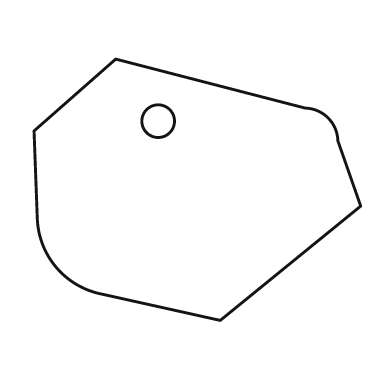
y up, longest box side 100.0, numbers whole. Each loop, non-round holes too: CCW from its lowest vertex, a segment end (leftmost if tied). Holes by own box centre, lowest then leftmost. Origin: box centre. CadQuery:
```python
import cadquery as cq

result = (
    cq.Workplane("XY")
    .moveTo(7.0, -40.0)
    .lineTo(50.0, -5.0)
    .lineTo(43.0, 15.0)
    .threePointArc((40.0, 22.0), (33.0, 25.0))
    .lineTo(-25.0, 40.0)
    .lineTo(-50.0, 18.0)
    .lineTo(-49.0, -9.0)
    .threePointArc((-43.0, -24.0), (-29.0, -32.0))
    .close()
    .moveTo(-12.0, 21.0)
    .circle(5.0)
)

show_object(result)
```